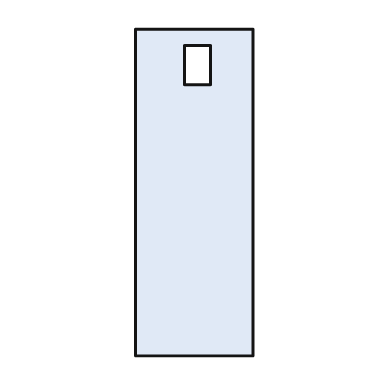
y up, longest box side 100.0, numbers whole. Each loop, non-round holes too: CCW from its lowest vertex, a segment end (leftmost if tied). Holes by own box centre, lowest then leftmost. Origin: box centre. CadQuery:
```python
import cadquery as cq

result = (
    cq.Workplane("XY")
    .moveTo(-18.0, -50.0)
    .lineTo(18.0, -50.0)
    .lineTo(18.0, 50.0)
    .lineTo(-18.0, 50.0)
    .close()
    .moveTo(-3.0, 33.0)
    .lineTo(5.0, 33.0)
    .lineTo(5.0, 45.0)
    .lineTo(-3.0, 45.0)
    .close()
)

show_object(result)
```